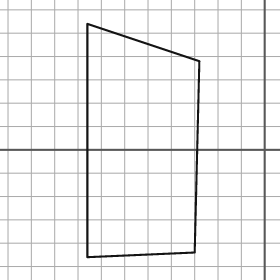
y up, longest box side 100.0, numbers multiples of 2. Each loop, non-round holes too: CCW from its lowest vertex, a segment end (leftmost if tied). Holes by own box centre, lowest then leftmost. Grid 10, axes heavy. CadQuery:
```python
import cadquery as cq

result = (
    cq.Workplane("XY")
    .moveTo(-76.0, -46.0)
    .lineTo(-30.0, -44.0)
    .lineTo(-28.0, 38.0)
    .lineTo(-76.0, 54.0)
    .close()
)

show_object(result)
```